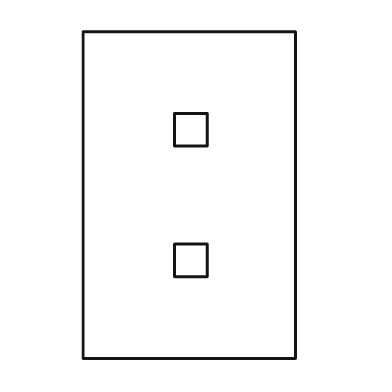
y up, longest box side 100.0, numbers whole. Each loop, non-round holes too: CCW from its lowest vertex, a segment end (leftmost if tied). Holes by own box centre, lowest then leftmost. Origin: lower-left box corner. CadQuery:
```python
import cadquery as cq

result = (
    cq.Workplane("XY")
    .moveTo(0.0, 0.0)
    .lineTo(65.0, 0.0)
    .lineTo(65.0, 100.0)
    .lineTo(0.0, 100.0)
    .close()
    .moveTo(28.0, 25.0)
    .lineTo(38.0, 25.0)
    .lineTo(38.0, 35.0)
    .lineTo(28.0, 35.0)
    .close()
    .moveTo(28.0, 65.0)
    .lineTo(38.0, 65.0)
    .lineTo(38.0, 75.0)
    .lineTo(28.0, 75.0)
    .close()
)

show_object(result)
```